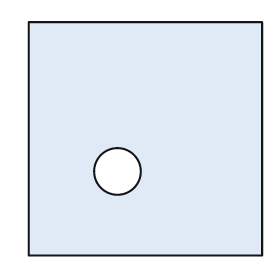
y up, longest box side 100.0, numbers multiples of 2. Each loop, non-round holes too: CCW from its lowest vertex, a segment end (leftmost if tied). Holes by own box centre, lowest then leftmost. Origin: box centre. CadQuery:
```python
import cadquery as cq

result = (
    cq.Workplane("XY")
    .moveTo(-50.0, -50.0)
    .lineTo(50.0, -50.0)
    .lineTo(50.0, 50.0)
    .lineTo(-50.0, 50.0)
    .close()
    .moveTo(-12.0, -14.0)
    .circle(10.0)
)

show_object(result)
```